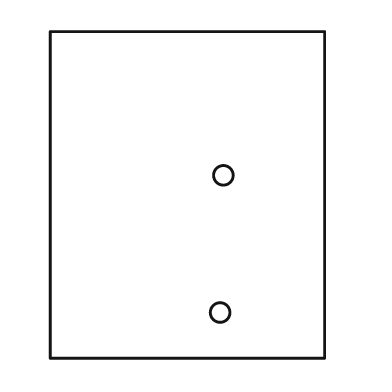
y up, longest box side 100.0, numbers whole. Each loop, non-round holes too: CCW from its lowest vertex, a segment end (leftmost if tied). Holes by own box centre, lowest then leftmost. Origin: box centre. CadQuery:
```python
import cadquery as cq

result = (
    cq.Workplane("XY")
    .moveTo(-42.0, -50.0)
    .lineTo(42.0, -50.0)
    .lineTo(42.0, 50.0)
    .lineTo(-42.0, 50.0)
    .close()
    .moveTo(10.0, -36.0)
    .circle(3.0)
    .moveTo(11.0, 6.0)
    .circle(3.0)
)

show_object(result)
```